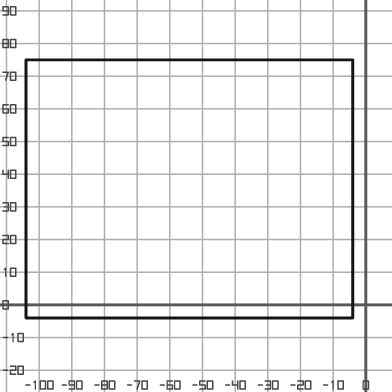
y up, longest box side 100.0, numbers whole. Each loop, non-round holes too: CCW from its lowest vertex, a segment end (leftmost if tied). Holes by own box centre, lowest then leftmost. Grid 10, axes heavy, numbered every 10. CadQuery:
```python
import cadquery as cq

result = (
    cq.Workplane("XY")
    .moveTo(-104.0, -4.0)
    .lineTo(-4.0, -4.0)
    .lineTo(-4.0, 75.0)
    .lineTo(-104.0, 75.0)
    .close()
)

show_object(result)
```